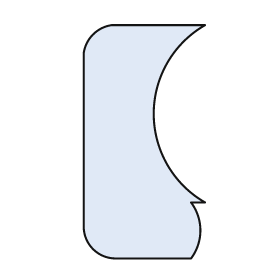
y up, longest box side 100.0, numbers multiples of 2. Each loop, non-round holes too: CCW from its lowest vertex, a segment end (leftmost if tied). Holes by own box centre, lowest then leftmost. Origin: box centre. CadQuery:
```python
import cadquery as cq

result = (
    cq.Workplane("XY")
    .moveTo(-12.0, -50.0)
    .lineTo(20.0, -50.0)
    .threePointArc((24.0, -38.0), (20.0, -26.0))
    .lineTo(26.0, -26.0)
    .threePointArc((4.0, 12.0), (26.0, 50.0))
    .lineTo(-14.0, 50.0)
    .threePointArc((-22.0, 46.0), (-26.0, 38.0))
    .lineTo(-26.0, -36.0)
    .threePointArc((-22.0, -46.0), (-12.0, -50.0))
    .close()
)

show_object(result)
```